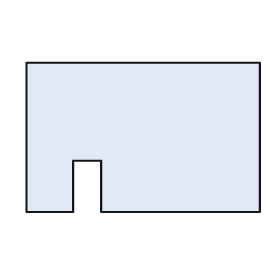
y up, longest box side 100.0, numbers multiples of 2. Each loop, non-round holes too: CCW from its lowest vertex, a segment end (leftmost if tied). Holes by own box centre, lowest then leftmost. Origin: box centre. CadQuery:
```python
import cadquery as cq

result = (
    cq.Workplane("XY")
    .moveTo(-50.0, -32.0)
    .lineTo(-30.0, -32.0)
    .lineTo(-30.0, -10.0)
    .lineTo(-18.0, -10.0)
    .lineTo(-18.0, -32.0)
    .lineTo(50.0, -32.0)
    .lineTo(50.0, 32.0)
    .lineTo(-50.0, 32.0)
    .close()
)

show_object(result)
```